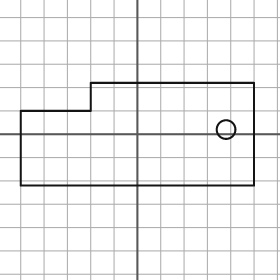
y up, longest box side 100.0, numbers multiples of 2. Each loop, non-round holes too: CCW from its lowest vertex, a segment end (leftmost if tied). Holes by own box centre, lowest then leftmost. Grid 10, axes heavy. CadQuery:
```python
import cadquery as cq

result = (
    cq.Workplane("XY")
    .moveTo(-50.0, -22.0)
    .lineTo(50.0, -22.0)
    .lineTo(50.0, 22.0)
    .lineTo(-20.0, 22.0)
    .lineTo(-20.0, 10.0)
    .lineTo(-50.0, 10.0)
    .close()
    .moveTo(38.0, 2.0)
    .circle(4.0)
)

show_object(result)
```